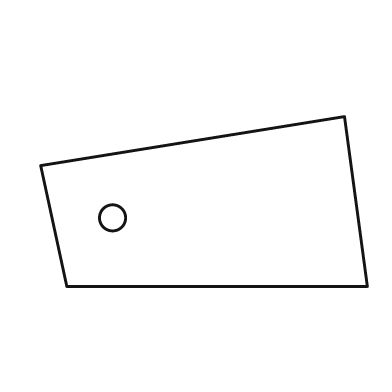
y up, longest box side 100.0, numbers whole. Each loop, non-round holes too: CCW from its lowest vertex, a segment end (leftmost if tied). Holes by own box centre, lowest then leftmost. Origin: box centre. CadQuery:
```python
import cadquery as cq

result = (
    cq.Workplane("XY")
    .moveTo(-42.0, -26.0)
    .lineTo(50.0, -26.0)
    .lineTo(43.0, 26.0)
    .lineTo(-50.0, 11.0)
    .close()
    .moveTo(-28.0, -5.0)
    .circle(4.0)
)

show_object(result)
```